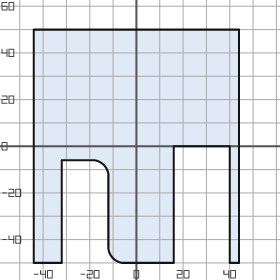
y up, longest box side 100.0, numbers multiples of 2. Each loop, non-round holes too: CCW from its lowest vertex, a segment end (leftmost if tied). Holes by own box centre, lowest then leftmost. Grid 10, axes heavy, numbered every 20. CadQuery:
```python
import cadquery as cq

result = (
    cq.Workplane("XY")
    .moveTo(-44.0, -50.0)
    .lineTo(-32.0, -50.0)
    .lineTo(-32.0, -6.0)
    .lineTo(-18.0, -6.0)
    .threePointArc((-14.0, -8.0), (-12.0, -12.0))
    .lineTo(-12.0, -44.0)
    .threePointArc((-10.0, -48.0), (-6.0, -50.0))
    .lineTo(16.0, -50.0)
    .lineTo(16.0, 0.0)
    .lineTo(40.0, 0.0)
    .lineTo(40.0, -50.0)
    .lineTo(44.0, -50.0)
    .lineTo(44.0, 50.0)
    .lineTo(-44.0, 50.0)
    .close()
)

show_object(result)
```